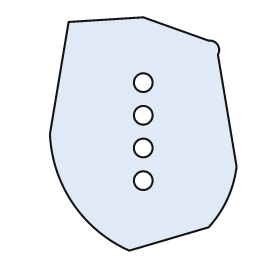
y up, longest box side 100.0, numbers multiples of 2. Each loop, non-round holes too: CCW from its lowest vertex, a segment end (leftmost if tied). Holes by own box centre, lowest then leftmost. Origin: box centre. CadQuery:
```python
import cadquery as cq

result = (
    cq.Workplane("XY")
    .moveTo(-6.0, -50.0)
    .lineTo(28.0, -40.0)
    .threePointArc((36.0, -28.0), (40.0, -14.0))
    .lineTo(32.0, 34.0)
    .threePointArc((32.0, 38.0), (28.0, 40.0))
    .lineTo(0.0, 50.0)
    .lineTo(-32.0, 48.0)
    .lineTo(-40.0, 0.0)
    .threePointArc((-30.0, -30.0), (-6.0, -50.0))
    .close()
    .moveTo(0.0, -20.0)
    .circle(4.0)
    .moveTo(0.0, -6.0)
    .circle(4.0)
    .moveTo(0.0, 8.0)
    .circle(4.0)
    .moveTo(0.0, 22.0)
    .circle(4.0)
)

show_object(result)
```